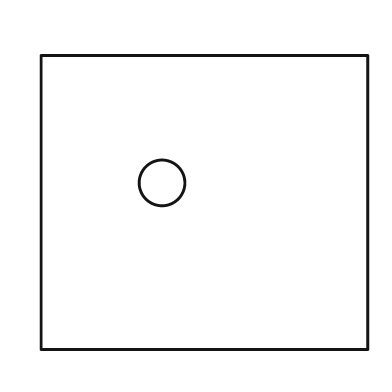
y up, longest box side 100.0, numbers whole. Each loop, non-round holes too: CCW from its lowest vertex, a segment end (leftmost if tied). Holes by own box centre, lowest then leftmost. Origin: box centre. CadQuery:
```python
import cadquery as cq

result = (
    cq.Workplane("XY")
    .moveTo(-50.0, -45.0)
    .lineTo(50.0, -45.0)
    .lineTo(50.0, 45.0)
    .lineTo(-50.0, 45.0)
    .close()
    .moveTo(-13.0, 6.0)
    .circle(7.0)
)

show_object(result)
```